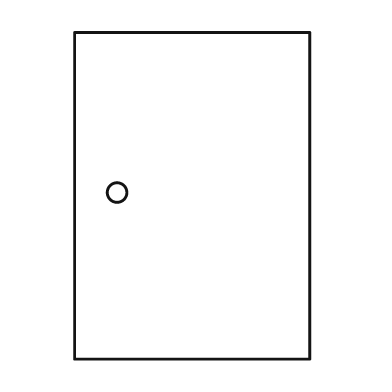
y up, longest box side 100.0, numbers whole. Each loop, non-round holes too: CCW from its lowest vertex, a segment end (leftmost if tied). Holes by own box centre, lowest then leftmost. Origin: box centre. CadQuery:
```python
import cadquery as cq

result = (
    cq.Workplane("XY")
    .moveTo(-36.0, -50.0)
    .lineTo(36.0, -50.0)
    .lineTo(36.0, 50.0)
    .lineTo(-36.0, 50.0)
    .close()
    .moveTo(-23.0, 1.0)
    .circle(3.0)
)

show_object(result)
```